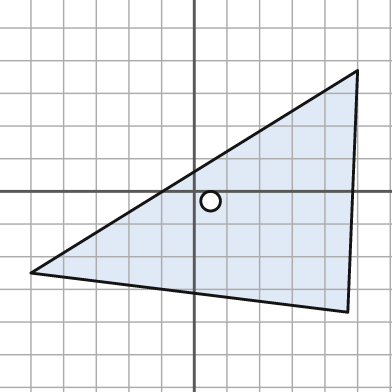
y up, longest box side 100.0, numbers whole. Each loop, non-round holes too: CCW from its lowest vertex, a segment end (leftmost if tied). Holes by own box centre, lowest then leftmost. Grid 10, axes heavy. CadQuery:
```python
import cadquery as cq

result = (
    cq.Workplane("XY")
    .moveTo(47.0, -37.0)
    .lineTo(50.0, 37.0)
    .lineTo(-50.0, -25.0)
    .close()
    .moveTo(5.0, -3.0)
    .circle(3.0)
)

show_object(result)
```